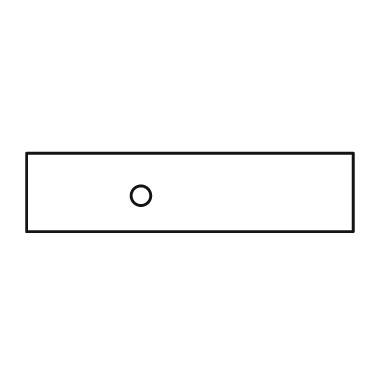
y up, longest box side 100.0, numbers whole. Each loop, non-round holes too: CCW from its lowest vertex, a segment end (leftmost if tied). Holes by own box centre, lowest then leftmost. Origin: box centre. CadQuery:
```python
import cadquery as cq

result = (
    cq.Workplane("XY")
    .moveTo(-50.0, -12.0)
    .lineTo(50.0, -12.0)
    .lineTo(50.0, 12.0)
    .lineTo(-50.0, 12.0)
    .close()
    .moveTo(-15.0, -1.0)
    .circle(3.0)
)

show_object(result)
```